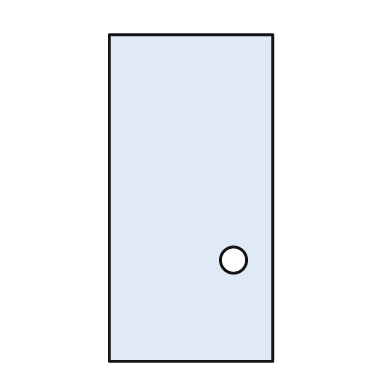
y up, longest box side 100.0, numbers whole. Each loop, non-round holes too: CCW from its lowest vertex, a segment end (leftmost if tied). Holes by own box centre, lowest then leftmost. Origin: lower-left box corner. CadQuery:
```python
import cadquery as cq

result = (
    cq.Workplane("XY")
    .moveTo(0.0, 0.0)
    .lineTo(50.0, 0.0)
    .lineTo(50.0, 100.0)
    .lineTo(0.0, 100.0)
    .close()
    .moveTo(38.0, 31.0)
    .circle(4.0)
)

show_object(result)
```